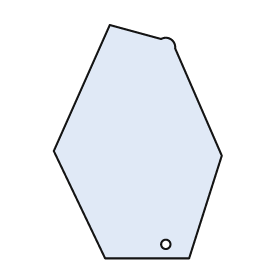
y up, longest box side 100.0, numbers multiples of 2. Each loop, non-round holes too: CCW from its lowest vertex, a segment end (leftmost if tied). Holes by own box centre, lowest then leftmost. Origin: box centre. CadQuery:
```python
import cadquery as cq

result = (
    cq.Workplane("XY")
    .moveTo(-14.0, -50.0)
    .lineTo(22.0, -50.0)
    .lineTo(36.0, -6.0)
    .lineTo(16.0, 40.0)
    .threePointArc((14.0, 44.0), (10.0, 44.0))
    .lineTo(-12.0, 50.0)
    .lineTo(-36.0, -4.0)
    .close()
    .moveTo(12.0, -44.0)
    .circle(2.0)
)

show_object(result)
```